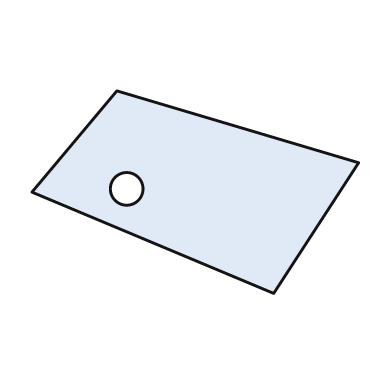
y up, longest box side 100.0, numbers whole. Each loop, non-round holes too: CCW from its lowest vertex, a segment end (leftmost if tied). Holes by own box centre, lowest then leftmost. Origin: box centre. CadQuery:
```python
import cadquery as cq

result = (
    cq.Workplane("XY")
    .moveTo(24.0, -31.0)
    .lineTo(50.0, 9.0)
    .lineTo(-24.0, 31.0)
    .lineTo(-50.0, 0.0)
    .close()
    .moveTo(-21.0, 1.0)
    .circle(5.0)
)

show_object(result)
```